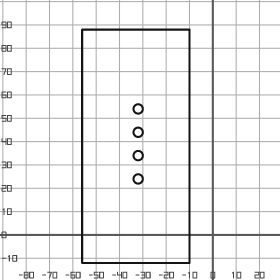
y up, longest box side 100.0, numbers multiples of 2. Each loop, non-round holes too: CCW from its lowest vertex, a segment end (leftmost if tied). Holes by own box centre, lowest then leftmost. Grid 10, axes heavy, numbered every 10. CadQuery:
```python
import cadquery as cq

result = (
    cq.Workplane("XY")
    .moveTo(-56.0, -12.0)
    .lineTo(-10.0, -12.0)
    .lineTo(-10.0, 88.0)
    .lineTo(-56.0, 88.0)
    .close()
    .moveTo(-32.0, 24.0)
    .circle(2.0)
    .moveTo(-32.0, 34.0)
    .circle(2.0)
    .moveTo(-32.0, 44.0)
    .circle(2.0)
    .moveTo(-32.0, 54.0)
    .circle(2.0)
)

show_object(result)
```